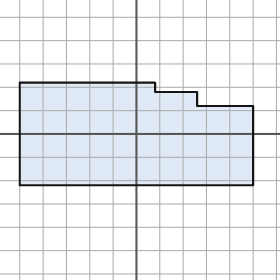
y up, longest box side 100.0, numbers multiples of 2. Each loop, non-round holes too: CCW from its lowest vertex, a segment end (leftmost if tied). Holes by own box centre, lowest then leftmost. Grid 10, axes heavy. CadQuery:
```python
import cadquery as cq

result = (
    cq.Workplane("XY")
    .moveTo(-50.0, -22.0)
    .lineTo(50.0, -22.0)
    .lineTo(50.0, 12.0)
    .lineTo(26.0, 12.0)
    .lineTo(26.0, 18.0)
    .lineTo(8.0, 18.0)
    .lineTo(8.0, 22.0)
    .lineTo(-50.0, 22.0)
    .close()
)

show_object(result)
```